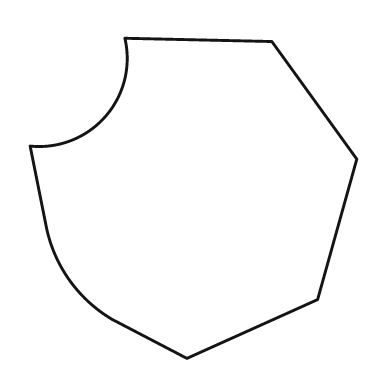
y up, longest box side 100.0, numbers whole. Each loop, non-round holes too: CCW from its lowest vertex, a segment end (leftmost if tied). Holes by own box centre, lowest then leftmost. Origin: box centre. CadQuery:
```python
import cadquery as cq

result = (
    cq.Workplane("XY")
    .moveTo(-2.0, -49.0)
    .lineTo(38.0, -31.0)
    .lineTo(50.0, 12.0)
    .lineTo(24.0, 48.0)
    .lineTo(-21.0, 49.0)
    .threePointArc((-27.0, 25.0), (-50.0, 16.0))
    .lineTo(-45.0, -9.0)
    .threePointArc((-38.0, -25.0), (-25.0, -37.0))
    .close()
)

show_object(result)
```